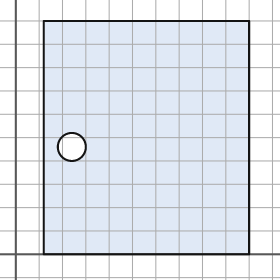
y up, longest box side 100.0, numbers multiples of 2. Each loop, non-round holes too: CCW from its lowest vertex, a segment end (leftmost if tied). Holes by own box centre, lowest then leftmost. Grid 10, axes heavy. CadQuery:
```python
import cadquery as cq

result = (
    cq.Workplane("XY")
    .moveTo(12.0, 0.0)
    .lineTo(100.0, 0.0)
    .lineTo(100.0, 100.0)
    .lineTo(12.0, 100.0)
    .close()
    .moveTo(24.0, 46.0)
    .circle(6.0)
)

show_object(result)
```